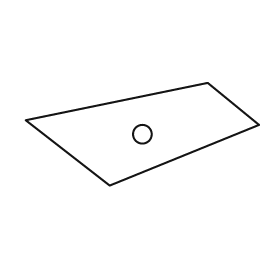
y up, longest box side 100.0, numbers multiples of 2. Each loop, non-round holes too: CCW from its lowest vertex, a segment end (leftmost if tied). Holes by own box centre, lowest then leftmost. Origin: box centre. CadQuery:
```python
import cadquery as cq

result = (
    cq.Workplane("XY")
    .moveTo(-14.0, -22.0)
    .lineTo(50.0, 4.0)
    .lineTo(28.0, 22.0)
    .lineTo(-50.0, 6.0)
    .close()
    .moveTo(0.0, 0.0)
    .circle(4.0)
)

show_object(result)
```